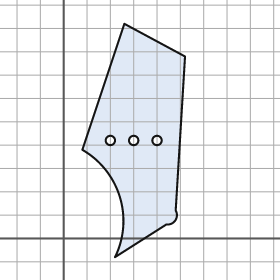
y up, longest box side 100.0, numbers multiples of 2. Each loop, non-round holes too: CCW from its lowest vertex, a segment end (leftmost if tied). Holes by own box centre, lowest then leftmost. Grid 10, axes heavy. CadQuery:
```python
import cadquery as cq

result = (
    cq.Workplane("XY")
    .moveTo(22.0, -8.0)
    .lineTo(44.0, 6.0)
    .threePointArc((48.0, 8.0), (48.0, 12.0))
    .lineTo(52.0, 78.0)
    .lineTo(26.0, 92.0)
    .lineTo(8.0, 38.0)
    .threePointArc((24.0, 18.0), (22.0, -8.0))
    .close()
    .moveTo(20.0, 42.0)
    .circle(2.0)
    .moveTo(30.0, 42.0)
    .circle(2.0)
    .moveTo(40.0, 42.0)
    .circle(2.0)
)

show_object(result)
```